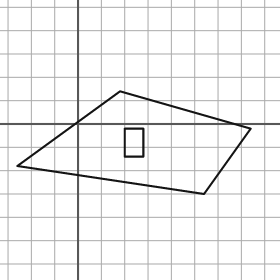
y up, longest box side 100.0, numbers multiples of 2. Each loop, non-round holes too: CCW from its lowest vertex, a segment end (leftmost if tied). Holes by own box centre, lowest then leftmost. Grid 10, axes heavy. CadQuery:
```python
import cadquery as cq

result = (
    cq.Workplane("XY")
    .moveTo(54.0, -30.0)
    .lineTo(74.0, -2.0)
    .lineTo(18.0, 14.0)
    .lineTo(-26.0, -18.0)
    .close()
    .moveTo(20.0, -14.0)
    .lineTo(28.0, -14.0)
    .lineTo(28.0, -2.0)
    .lineTo(20.0, -2.0)
    .close()
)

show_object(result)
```